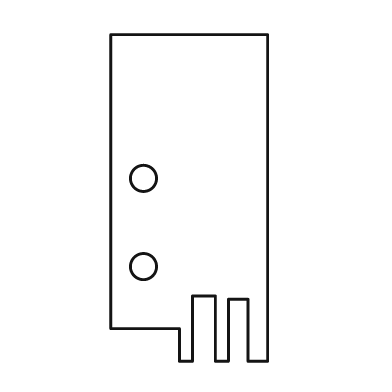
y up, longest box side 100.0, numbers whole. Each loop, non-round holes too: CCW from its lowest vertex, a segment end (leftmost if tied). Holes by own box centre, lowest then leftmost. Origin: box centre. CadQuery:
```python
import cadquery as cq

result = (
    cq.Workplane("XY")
    .moveTo(-3.0, -50.0)
    .lineTo(1.0, -50.0)
    .lineTo(1.0, -30.0)
    .lineTo(8.0, -30.0)
    .lineTo(8.0, -50.0)
    .lineTo(12.0, -50.0)
    .lineTo(12.0, -31.0)
    .lineTo(18.0, -31.0)
    .lineTo(18.0, -50.0)
    .lineTo(24.0, -50.0)
    .lineTo(24.0, 50.0)
    .lineTo(-24.0, 50.0)
    .lineTo(-24.0, -40.0)
    .lineTo(-3.0, -40.0)
    .close()
    .moveTo(-14.0, -21.0)
    .circle(4.0)
    .moveTo(-14.0, 6.0)
    .circle(4.0)
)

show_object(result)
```